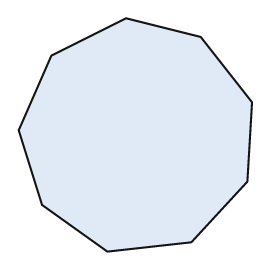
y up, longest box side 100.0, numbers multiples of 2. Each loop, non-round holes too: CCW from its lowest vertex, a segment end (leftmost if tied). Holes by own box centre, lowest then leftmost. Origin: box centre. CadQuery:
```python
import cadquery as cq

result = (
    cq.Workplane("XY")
    .moveTo(-12.0, -50.0)
    .lineTo(24.0, -46.0)
    .lineTo(48.0, -20.0)
    .lineTo(50.0, 14.0)
    .lineTo(28.0, 42.0)
    .lineTo(-4.0, 50.0)
    .lineTo(-36.0, 34.0)
    .lineTo(-50.0, 2.0)
    .lineTo(-40.0, -30.0)
    .close()
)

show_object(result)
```